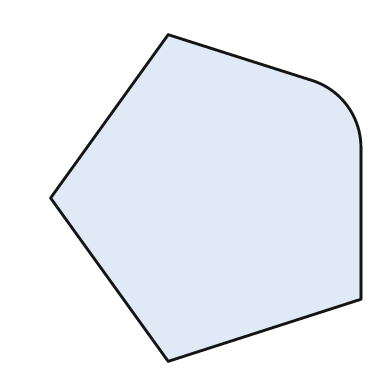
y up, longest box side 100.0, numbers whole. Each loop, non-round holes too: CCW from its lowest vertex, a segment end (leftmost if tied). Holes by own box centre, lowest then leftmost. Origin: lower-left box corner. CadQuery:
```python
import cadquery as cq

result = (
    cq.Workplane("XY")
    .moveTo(36.0, 0.0)
    .lineTo(95.0, 19.0)
    .lineTo(95.0, 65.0)
    .threePointArc((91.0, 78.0), (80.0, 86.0))
    .lineTo(36.0, 100.0)
    .lineTo(0.0, 50.0)
    .close()
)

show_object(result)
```